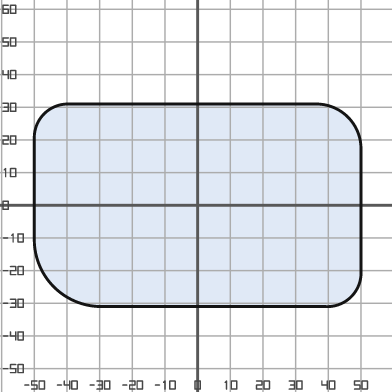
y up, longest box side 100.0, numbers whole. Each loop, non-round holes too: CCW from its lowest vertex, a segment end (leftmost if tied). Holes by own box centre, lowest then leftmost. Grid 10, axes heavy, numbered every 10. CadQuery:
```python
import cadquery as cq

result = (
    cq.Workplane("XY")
    .moveTo(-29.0, -31.0)
    .lineTo(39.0, -31.0)
    .threePointArc((47.0, -28.0), (50.0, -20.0))
    .lineTo(50.0, 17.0)
    .threePointArc((46.0, 27.0), (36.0, 31.0))
    .lineTo(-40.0, 31.0)
    .threePointArc((-47.0, 28.0), (-50.0, 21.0))
    .lineTo(-50.0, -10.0)
    .threePointArc((-44.0, -25.0), (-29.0, -31.0))
    .close()
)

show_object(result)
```